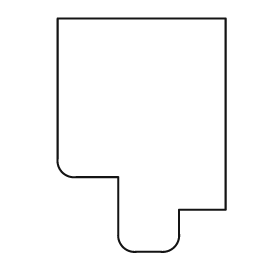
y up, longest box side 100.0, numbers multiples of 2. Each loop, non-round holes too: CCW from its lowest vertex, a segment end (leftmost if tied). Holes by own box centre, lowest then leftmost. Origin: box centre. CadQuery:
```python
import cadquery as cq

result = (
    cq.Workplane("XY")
    .moveTo(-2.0, -50.0)
    .lineTo(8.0, -50.0)
    .threePointArc((14.0, -48.0), (16.0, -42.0))
    .lineTo(16.0, -32.0)
    .lineTo(36.0, -32.0)
    .lineTo(36.0, 50.0)
    .lineTo(-36.0, 50.0)
    .lineTo(-36.0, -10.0)
    .threePointArc((-34.0, -16.0), (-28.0, -18.0))
    .lineTo(-10.0, -18.0)
    .lineTo(-10.0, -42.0)
    .threePointArc((-8.0, -48.0), (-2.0, -50.0))
    .close()
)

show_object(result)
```